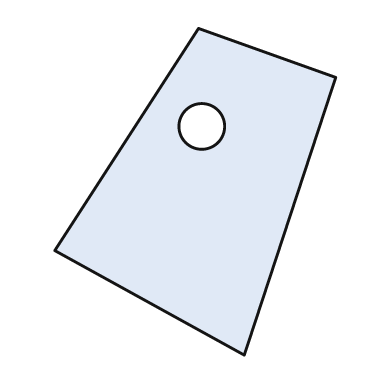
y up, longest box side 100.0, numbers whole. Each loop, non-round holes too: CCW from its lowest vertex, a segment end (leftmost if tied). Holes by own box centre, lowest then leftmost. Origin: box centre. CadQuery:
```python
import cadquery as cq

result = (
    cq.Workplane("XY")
    .moveTo(15.0, -50.0)
    .lineTo(43.0, 35.0)
    .lineTo(1.0, 50.0)
    .lineTo(-43.0, -18.0)
    .close()
    .moveTo(2.0, 20.0)
    .circle(7.0)
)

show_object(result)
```